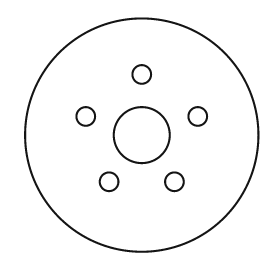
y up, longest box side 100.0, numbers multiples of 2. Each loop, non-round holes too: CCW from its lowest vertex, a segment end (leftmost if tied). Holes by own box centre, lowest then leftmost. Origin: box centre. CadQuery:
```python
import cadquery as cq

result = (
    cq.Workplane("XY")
    .moveTo(0.0, 0.0)
    .circle(50.0)
    .moveTo(-14.0, -20.0)
    .circle(4.0)
    .moveTo(14.0, -20.0)
    .circle(4.0)
    .moveTo(0.0, 0.0)
    .circle(12.0)
    .moveTo(-24.0, 8.0)
    .circle(4.0)
    .moveTo(24.0, 8.0)
    .circle(4.0)
    .moveTo(0.0, 26.0)
    .circle(4.0)
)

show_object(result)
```